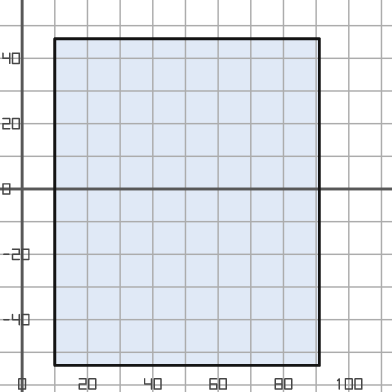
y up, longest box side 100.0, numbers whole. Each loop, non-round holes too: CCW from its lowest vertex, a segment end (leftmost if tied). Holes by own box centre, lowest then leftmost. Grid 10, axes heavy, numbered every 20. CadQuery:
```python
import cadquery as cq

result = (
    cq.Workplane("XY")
    .moveTo(10.0, -54.0)
    .lineTo(91.0, -54.0)
    .lineTo(91.0, 46.0)
    .lineTo(10.0, 46.0)
    .close()
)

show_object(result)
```